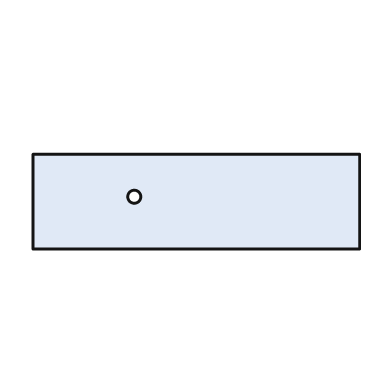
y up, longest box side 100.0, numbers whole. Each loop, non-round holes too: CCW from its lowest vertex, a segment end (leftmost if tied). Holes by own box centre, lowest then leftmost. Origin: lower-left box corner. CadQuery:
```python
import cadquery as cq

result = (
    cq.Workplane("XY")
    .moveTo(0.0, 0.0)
    .lineTo(100.0, 0.0)
    .lineTo(100.0, 29.0)
    .lineTo(0.0, 29.0)
    .close()
    .moveTo(31.0, 16.0)
    .circle(2.0)
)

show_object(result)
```